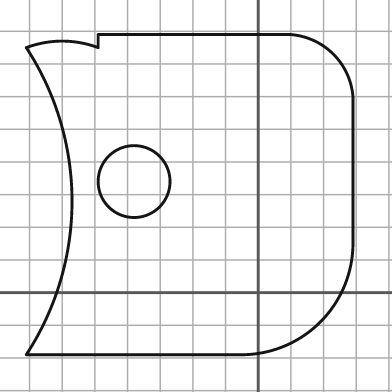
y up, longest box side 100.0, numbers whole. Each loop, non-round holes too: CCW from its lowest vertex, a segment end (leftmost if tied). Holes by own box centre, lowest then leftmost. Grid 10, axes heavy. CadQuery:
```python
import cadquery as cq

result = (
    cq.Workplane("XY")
    .moveTo(-71.0, -19.0)
    .lineTo(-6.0, -19.0)
    .threePointArc((19.0, -9.0), (29.0, 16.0))
    .lineTo(29.0, 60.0)
    .threePointArc((23.0, 73.0), (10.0, 79.0))
    .lineTo(-49.0, 79.0)
    .lineTo(-49.0, 75.0)
    .threePointArc((-60.0, 77.0), (-71.0, 75.0))
    .threePointArc((-57.0, 28.0), (-71.0, -19.0))
    .close()
    .moveTo(-38.0, 34.0)
    .circle(11.0)
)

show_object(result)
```